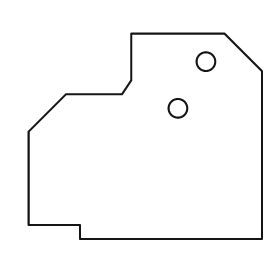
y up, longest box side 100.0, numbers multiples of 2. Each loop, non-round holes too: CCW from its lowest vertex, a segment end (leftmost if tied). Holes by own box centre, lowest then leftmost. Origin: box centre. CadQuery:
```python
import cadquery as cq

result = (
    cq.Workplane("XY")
    .moveTo(-28.0, -44.0)
    .lineTo(50.0, -44.0)
    .lineTo(50.0, 28.0)
    .lineTo(34.0, 44.0)
    .lineTo(-6.0, 44.0)
    .lineTo(-6.0, 24.0)
    .lineTo(-10.0, 18.0)
    .lineTo(-34.0, 18.0)
    .lineTo(-50.0, 2.0)
    .lineTo(-50.0, -38.0)
    .lineTo(-28.0, -38.0)
    .close()
    .moveTo(14.0, 12.0)
    .circle(4.0)
    .moveTo(26.0, 32.0)
    .circle(4.0)
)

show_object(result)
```